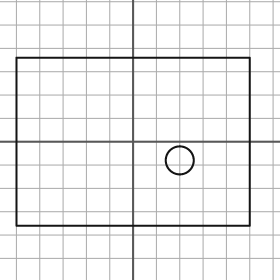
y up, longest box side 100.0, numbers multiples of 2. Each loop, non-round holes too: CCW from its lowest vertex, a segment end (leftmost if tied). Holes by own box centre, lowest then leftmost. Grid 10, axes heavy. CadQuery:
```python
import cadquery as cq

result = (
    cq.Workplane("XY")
    .moveTo(-50.0, -36.0)
    .lineTo(50.0, -36.0)
    .lineTo(50.0, 36.0)
    .lineTo(-50.0, 36.0)
    .close()
    .moveTo(20.0, -8.0)
    .circle(6.0)
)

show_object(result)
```